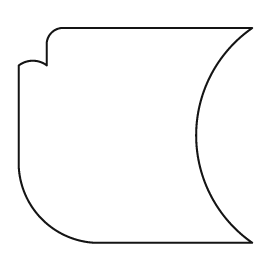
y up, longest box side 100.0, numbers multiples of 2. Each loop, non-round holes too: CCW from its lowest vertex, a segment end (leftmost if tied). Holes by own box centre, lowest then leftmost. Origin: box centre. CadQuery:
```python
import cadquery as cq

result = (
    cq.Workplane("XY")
    .moveTo(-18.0, -46.0)
    .lineTo(50.0, -46.0)
    .threePointArc((26.0, 0.0), (50.0, 46.0))
    .lineTo(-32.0, 46.0)
    .threePointArc((-36.0, 44.0), (-38.0, 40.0))
    .lineTo(-38.0, 30.0)
    .threePointArc((-44.0, 32.0), (-50.0, 30.0))
    .lineTo(-50.0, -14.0)
    .threePointArc((-40.0, -36.0), (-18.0, -46.0))
    .close()
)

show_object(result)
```